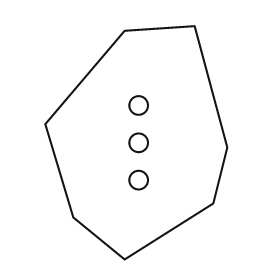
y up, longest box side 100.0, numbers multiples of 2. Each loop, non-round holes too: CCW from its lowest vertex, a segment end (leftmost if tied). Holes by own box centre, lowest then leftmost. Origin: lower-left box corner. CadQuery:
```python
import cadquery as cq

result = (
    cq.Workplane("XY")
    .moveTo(34.0, 0.0)
    .lineTo(72.0, 24.0)
    .lineTo(78.0, 48.0)
    .lineTo(64.0, 100.0)
    .lineTo(34.0, 98.0)
    .lineTo(0.0, 58.0)
    .lineTo(12.0, 18.0)
    .close()
    .moveTo(40.0, 34.0)
    .circle(4.0)
    .moveTo(40.0, 50.0)
    .circle(4.0)
    .moveTo(40.0, 66.0)
    .circle(4.0)
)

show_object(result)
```